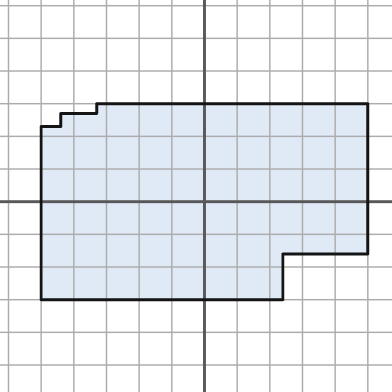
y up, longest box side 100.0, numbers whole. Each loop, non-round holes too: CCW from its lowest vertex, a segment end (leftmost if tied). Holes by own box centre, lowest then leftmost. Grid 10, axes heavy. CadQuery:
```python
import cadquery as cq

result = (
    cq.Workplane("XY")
    .moveTo(-50.0, -30.0)
    .lineTo(24.0, -30.0)
    .lineTo(24.0, -16.0)
    .lineTo(50.0, -16.0)
    .lineTo(50.0, 30.0)
    .lineTo(-33.0, 30.0)
    .lineTo(-33.0, 27.0)
    .lineTo(-44.0, 27.0)
    .lineTo(-44.0, 23.0)
    .lineTo(-50.0, 23.0)
    .close()
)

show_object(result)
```